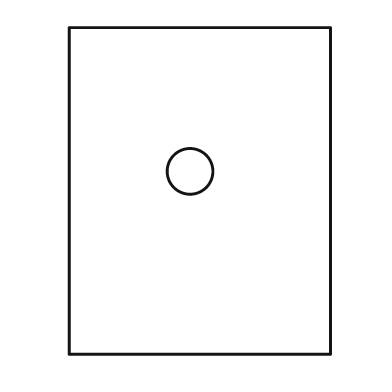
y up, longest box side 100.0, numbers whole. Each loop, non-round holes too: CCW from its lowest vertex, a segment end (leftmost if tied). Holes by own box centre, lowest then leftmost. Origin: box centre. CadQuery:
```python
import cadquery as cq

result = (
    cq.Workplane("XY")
    .moveTo(-40.0, -50.0)
    .lineTo(40.0, -50.0)
    .lineTo(40.0, 50.0)
    .lineTo(-40.0, 50.0)
    .close()
    .moveTo(-3.0, 6.0)
    .circle(7.0)
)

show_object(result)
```